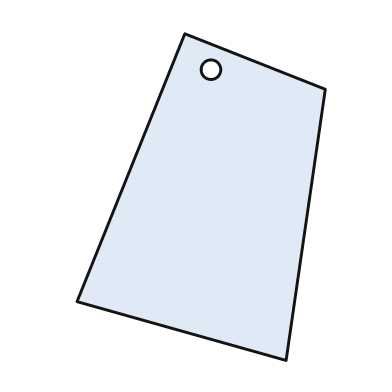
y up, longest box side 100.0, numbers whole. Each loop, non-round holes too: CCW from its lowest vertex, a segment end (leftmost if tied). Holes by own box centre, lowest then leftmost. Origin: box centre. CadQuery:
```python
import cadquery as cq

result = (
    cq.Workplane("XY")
    .moveTo(26.0, -50.0)
    .lineTo(38.0, 33.0)
    .lineTo(-5.0, 50.0)
    .lineTo(-38.0, -32.0)
    .close()
    .moveTo(3.0, 39.0)
    .circle(3.0)
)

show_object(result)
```